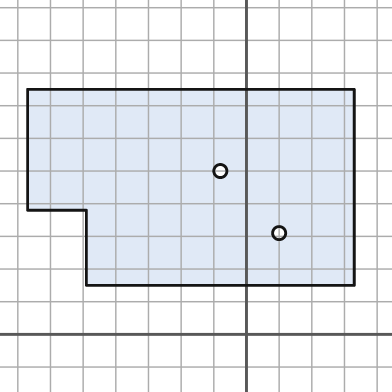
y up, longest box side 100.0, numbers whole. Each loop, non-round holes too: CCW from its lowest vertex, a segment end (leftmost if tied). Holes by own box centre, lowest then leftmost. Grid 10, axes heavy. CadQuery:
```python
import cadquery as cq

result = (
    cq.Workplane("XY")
    .moveTo(-49.0, 15.0)
    .lineTo(33.0, 15.0)
    .lineTo(33.0, 75.0)
    .lineTo(-67.0, 75.0)
    .lineTo(-67.0, 38.0)
    .lineTo(-49.0, 38.0)
    .close()
    .moveTo(10.0, 31.0)
    .circle(2.0)
    .moveTo(-8.0, 50.0)
    .circle(2.0)
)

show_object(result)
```